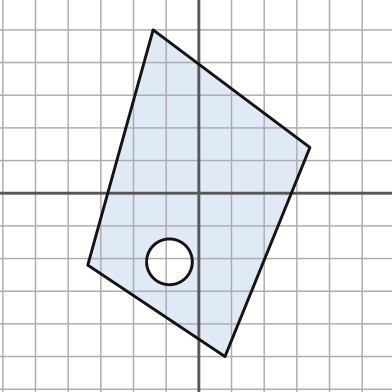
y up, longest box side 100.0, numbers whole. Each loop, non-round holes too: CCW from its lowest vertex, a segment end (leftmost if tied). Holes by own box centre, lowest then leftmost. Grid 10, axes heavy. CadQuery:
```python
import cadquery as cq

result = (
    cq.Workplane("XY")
    .moveTo(8.0, -50.0)
    .lineTo(34.0, 14.0)
    .lineTo(-14.0, 50.0)
    .lineTo(-34.0, -22.0)
    .close()
    .moveTo(-9.0, -21.0)
    .circle(7.0)
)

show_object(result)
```